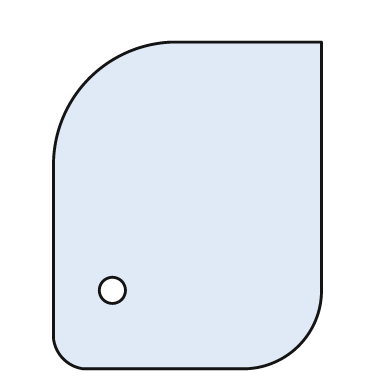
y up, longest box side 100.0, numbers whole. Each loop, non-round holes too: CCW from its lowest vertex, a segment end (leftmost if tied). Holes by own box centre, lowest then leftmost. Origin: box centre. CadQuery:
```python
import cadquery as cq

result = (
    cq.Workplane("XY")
    .moveTo(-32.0, -50.0)
    .lineTo(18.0, -50.0)
    .threePointArc((34.0, -43.0), (41.0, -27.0))
    .lineTo(41.0, 50.0)
    .lineTo(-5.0, 50.0)
    .threePointArc((-30.0, 39.0), (-41.0, 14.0))
    .lineTo(-41.0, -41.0)
    .threePointArc((-38.0, -47.0), (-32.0, -50.0))
    .close()
    .moveTo(-23.0, -26.0)
    .circle(4.0)
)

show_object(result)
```